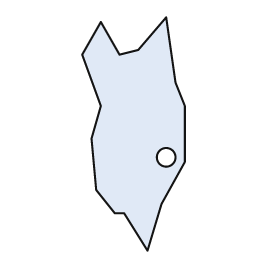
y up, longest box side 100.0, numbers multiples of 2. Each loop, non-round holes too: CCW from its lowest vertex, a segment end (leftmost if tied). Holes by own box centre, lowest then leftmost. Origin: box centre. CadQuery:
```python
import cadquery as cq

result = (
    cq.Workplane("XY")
    .moveTo(6.0, -50.0)
    .lineTo(12.0, -30.0)
    .lineTo(22.0, -12.0)
    .lineTo(22.0, 12.0)
    .lineTo(18.0, 22.0)
    .lineTo(14.0, 50.0)
    .lineTo(2.0, 36.0)
    .lineTo(-6.0, 34.0)
    .lineTo(-14.0, 48.0)
    .lineTo(-22.0, 34.0)
    .lineTo(-14.0, 12.0)
    .lineTo(-18.0, -2.0)
    .lineTo(-16.0, -24.0)
    .lineTo(-8.0, -34.0)
    .lineTo(-4.0, -34.0)
    .close()
    .moveTo(14.0, -10.0)
    .circle(4.0)
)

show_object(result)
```